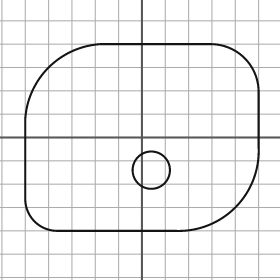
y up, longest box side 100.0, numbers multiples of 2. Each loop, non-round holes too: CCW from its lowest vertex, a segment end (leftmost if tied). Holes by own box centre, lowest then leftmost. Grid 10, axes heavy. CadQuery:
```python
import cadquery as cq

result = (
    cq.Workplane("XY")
    .moveTo(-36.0, -40.0)
    .lineTo(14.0, -40.0)
    .threePointArc((40.0, -30.0), (50.0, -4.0))
    .lineTo(50.0, 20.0)
    .threePointArc((44.0, 34.0), (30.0, 40.0))
    .lineTo(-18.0, 40.0)
    .threePointArc((-40.0, 30.0), (-50.0, 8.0))
    .lineTo(-50.0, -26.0)
    .threePointArc((-46.0, -36.0), (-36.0, -40.0))
    .close()
    .moveTo(4.0, -14.0)
    .circle(8.0)
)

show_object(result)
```